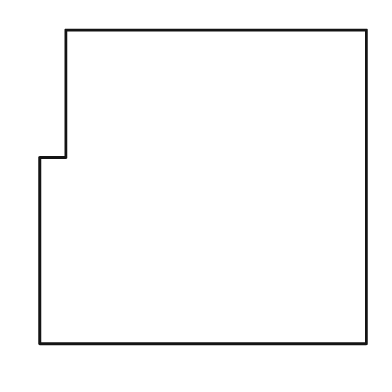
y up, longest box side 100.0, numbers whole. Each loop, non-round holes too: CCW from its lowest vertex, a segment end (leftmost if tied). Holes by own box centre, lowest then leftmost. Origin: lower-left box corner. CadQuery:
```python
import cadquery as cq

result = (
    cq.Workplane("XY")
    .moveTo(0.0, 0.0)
    .lineTo(100.0, 0.0)
    .lineTo(100.0, 96.0)
    .lineTo(8.0, 96.0)
    .lineTo(8.0, 57.0)
    .lineTo(0.0, 57.0)
    .close()
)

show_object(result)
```